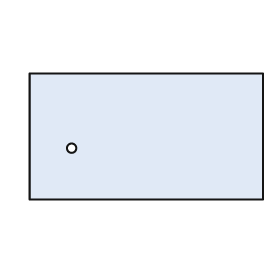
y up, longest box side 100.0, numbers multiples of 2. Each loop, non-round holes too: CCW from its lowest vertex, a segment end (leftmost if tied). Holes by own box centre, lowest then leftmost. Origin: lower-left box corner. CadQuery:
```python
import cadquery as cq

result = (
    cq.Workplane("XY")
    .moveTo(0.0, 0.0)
    .lineTo(100.0, 0.0)
    .lineTo(100.0, 54.0)
    .lineTo(0.0, 54.0)
    .close()
    .moveTo(18.0, 22.0)
    .circle(2.0)
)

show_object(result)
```